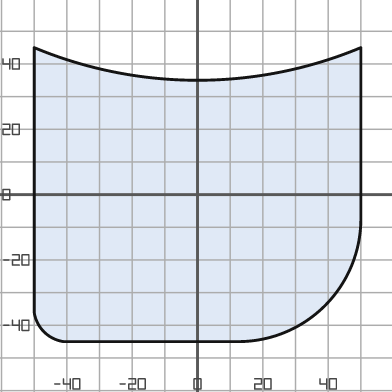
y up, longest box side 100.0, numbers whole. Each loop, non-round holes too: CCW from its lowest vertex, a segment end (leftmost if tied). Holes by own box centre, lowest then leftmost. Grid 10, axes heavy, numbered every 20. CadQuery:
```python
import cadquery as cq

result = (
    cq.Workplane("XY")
    .moveTo(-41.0, -45.0)
    .lineTo(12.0, -45.0)
    .threePointArc((39.0, -34.0), (50.0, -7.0))
    .lineTo(50.0, 45.0)
    .threePointArc((0.0, 35.0), (-50.0, 45.0))
    .lineTo(-50.0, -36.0)
    .threePointArc((-47.0, -42.0), (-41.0, -45.0))
    .close()
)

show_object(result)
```